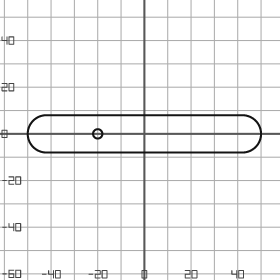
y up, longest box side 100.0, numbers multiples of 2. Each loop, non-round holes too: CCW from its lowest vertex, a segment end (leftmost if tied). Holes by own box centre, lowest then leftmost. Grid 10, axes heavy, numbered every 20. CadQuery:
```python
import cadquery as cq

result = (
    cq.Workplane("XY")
    .moveTo(-42.0, -8.0)
    .lineTo(42.0, -8.0)
    .threePointArc((50.0, 0.0), (42.0, 8.0))
    .lineTo(-42.0, 8.0)
    .threePointArc((-50.0, 0.0), (-42.0, -8.0))
    .close()
    .moveTo(-20.0, 0.0)
    .circle(2.0)
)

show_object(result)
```